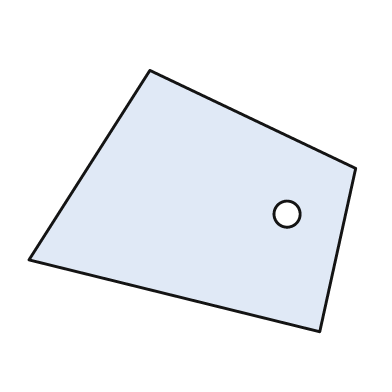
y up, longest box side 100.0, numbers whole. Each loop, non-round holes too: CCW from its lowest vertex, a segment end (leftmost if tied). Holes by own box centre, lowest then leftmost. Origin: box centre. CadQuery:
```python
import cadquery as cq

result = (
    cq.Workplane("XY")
    .moveTo(39.0, -40.0)
    .lineTo(50.0, 10.0)
    .lineTo(-13.0, 40.0)
    .lineTo(-50.0, -18.0)
    .close()
    .moveTo(29.0, -4.0)
    .circle(4.0)
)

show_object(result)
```